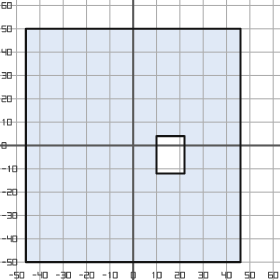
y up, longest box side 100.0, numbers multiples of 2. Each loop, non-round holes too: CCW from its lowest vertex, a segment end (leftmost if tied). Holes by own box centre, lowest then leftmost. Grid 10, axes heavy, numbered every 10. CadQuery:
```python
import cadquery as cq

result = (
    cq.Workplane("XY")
    .moveTo(-46.0, -50.0)
    .lineTo(46.0, -50.0)
    .lineTo(46.0, 50.0)
    .lineTo(-46.0, 50.0)
    .close()
    .moveTo(10.0, -12.0)
    .lineTo(22.0, -12.0)
    .lineTo(22.0, 4.0)
    .lineTo(10.0, 4.0)
    .close()
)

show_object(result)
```